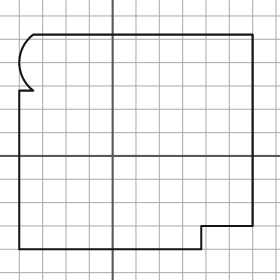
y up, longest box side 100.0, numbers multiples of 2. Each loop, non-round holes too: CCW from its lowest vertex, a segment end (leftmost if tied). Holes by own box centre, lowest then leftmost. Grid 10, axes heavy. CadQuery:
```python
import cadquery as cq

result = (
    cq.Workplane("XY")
    .moveTo(-40.0, -40.0)
    .lineTo(38.0, -40.0)
    .lineTo(38.0, -30.0)
    .lineTo(60.0, -30.0)
    .lineTo(60.0, 52.0)
    .lineTo(-34.0, 52.0)
    .threePointArc((-40.0, 40.0), (-34.0, 28.0))
    .lineTo(-40.0, 28.0)
    .close()
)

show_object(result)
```